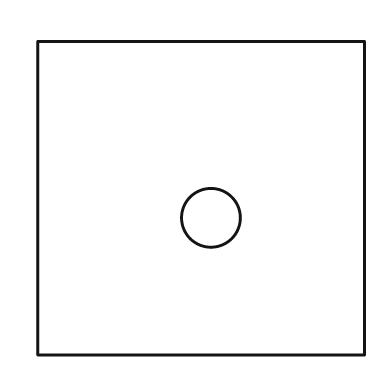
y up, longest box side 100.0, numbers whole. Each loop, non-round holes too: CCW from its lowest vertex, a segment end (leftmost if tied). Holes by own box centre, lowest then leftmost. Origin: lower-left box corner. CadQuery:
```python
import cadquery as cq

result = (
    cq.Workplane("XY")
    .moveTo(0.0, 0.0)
    .lineTo(100.0, 0.0)
    .lineTo(100.0, 96.0)
    .lineTo(0.0, 96.0)
    .close()
    .moveTo(53.0, 42.0)
    .circle(9.0)
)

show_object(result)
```